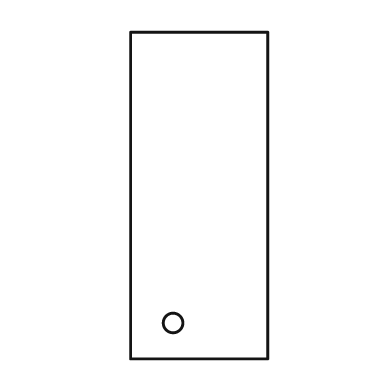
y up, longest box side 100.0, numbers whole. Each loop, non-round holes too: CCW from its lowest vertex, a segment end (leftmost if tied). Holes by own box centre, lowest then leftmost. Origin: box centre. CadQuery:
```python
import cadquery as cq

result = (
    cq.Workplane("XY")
    .moveTo(-21.0, -50.0)
    .lineTo(21.0, -50.0)
    .lineTo(21.0, 50.0)
    .lineTo(-21.0, 50.0)
    .close()
    .moveTo(-8.0, -39.0)
    .circle(3.0)
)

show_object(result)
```